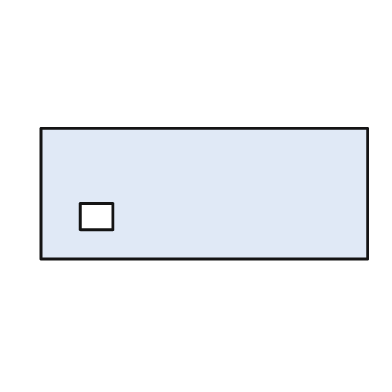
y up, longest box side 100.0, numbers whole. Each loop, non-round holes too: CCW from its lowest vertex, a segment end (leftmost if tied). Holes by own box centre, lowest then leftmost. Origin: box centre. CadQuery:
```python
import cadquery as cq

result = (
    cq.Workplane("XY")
    .moveTo(-50.0, -20.0)
    .lineTo(50.0, -20.0)
    .lineTo(50.0, 20.0)
    .lineTo(-50.0, 20.0)
    .close()
    .moveTo(-38.0, -11.0)
    .lineTo(-28.0, -11.0)
    .lineTo(-28.0, -3.0)
    .lineTo(-38.0, -3.0)
    .close()
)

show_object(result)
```